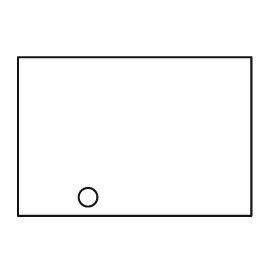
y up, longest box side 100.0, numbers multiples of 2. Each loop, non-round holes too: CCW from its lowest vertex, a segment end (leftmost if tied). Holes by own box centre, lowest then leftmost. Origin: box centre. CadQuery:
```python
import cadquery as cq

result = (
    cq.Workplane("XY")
    .moveTo(-50.0, -34.0)
    .lineTo(50.0, -34.0)
    .lineTo(50.0, 34.0)
    .lineTo(-50.0, 34.0)
    .close()
    .moveTo(-20.0, -26.0)
    .circle(4.0)
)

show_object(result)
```